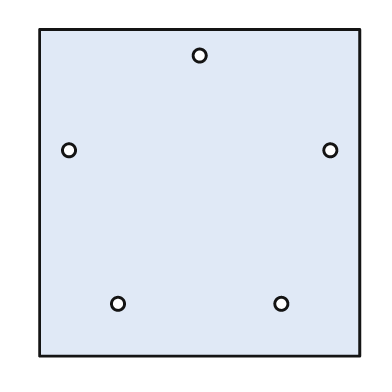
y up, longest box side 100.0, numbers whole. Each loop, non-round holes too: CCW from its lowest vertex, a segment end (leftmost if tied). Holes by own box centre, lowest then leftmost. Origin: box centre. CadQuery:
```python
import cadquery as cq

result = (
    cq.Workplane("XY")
    .moveTo(-49.0, -50.0)
    .lineTo(49.0, -50.0)
    .lineTo(49.0, 50.0)
    .lineTo(-49.0, 50.0)
    .close()
    .moveTo(-25.0, -34.0)
    .circle(2.0)
    .moveTo(25.0, -34.0)
    .circle(2.0)
    .moveTo(-40.0, 13.0)
    .circle(2.0)
    .moveTo(40.0, 13.0)
    .circle(2.0)
    .moveTo(0.0, 42.0)
    .circle(2.0)
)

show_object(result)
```